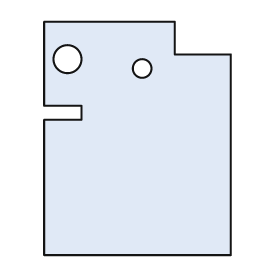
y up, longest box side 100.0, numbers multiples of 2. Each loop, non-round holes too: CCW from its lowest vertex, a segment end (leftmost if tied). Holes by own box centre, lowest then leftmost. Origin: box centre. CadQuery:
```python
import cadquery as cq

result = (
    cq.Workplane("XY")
    .moveTo(-40.0, -50.0)
    .lineTo(40.0, -50.0)
    .lineTo(40.0, 36.0)
    .lineTo(16.0, 36.0)
    .lineTo(16.0, 50.0)
    .lineTo(-40.0, 50.0)
    .lineTo(-40.0, 14.0)
    .lineTo(-24.0, 14.0)
    .lineTo(-24.0, 8.0)
    .lineTo(-40.0, 8.0)
    .close()
    .moveTo(2.0, 30.0)
    .circle(4.0)
    .moveTo(-30.0, 34.0)
    .circle(6.0)
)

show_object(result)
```